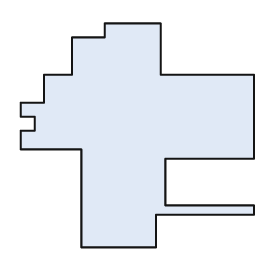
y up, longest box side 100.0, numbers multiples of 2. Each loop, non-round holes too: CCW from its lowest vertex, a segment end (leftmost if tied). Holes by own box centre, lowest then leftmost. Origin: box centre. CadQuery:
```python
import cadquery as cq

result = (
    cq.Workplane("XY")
    .moveTo(-24.0, -48.0)
    .lineTo(8.0, -48.0)
    .lineTo(8.0, -34.0)
    .lineTo(50.0, -34.0)
    .lineTo(50.0, -30.0)
    .lineTo(12.0, -30.0)
    .lineTo(12.0, -10.0)
    .lineTo(50.0, -10.0)
    .lineTo(50.0, 26.0)
    .lineTo(10.0, 26.0)
    .lineTo(10.0, 48.0)
    .lineTo(-14.0, 48.0)
    .lineTo(-14.0, 42.0)
    .lineTo(-28.0, 42.0)
    .lineTo(-28.0, 26.0)
    .lineTo(-40.0, 26.0)
    .lineTo(-40.0, 14.0)
    .lineTo(-50.0, 14.0)
    .lineTo(-50.0, 8.0)
    .lineTo(-44.0, 8.0)
    .lineTo(-44.0, 2.0)
    .lineTo(-50.0, 2.0)
    .lineTo(-50.0, -6.0)
    .lineTo(-24.0, -6.0)
    .close()
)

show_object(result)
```